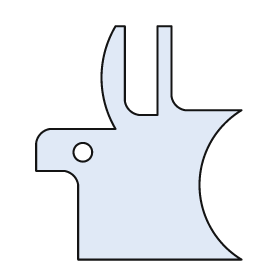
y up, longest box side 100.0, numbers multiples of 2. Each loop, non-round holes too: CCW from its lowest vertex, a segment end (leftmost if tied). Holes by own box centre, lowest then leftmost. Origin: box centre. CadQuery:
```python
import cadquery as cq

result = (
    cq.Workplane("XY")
    .moveTo(-26.0, -50.0)
    .lineTo(44.0, -50.0)
    .threePointArc((26.0, -18.0), (44.0, 14.0))
    .lineTo(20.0, 14.0)
    .threePointArc((16.0, 16.0), (14.0, 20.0))
    .lineTo(14.0, 50.0)
    .lineTo(8.0, 50.0)
    .lineTo(8.0, 12.0)
    .lineTo(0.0, 12.0)
    .threePointArc((-4.0, 14.0), (-6.0, 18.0))
    .lineTo(-6.0, 50.0)
    .lineTo(-10.0, 50.0)
    .threePointArc((-16.0, 28.0), (-10.0, 6.0))
    .lineTo(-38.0, 6.0)
    .threePointArc((-42.0, 4.0), (-44.0, 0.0))
    .lineTo(-44.0, -12.0)
    .lineTo(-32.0, -12.0)
    .threePointArc((-28.0, -14.0), (-26.0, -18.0))
    .close()
    .moveTo(-24.0, -4.0)
    .circle(4.0)
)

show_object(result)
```